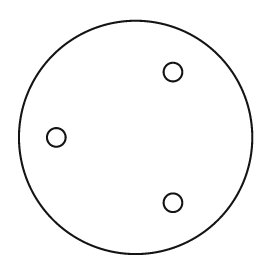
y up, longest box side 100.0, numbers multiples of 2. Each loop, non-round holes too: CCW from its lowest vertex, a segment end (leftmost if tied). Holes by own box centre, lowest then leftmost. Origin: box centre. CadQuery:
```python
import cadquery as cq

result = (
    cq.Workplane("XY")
    .moveTo(0.0, 0.0)
    .circle(50.0)
    .moveTo(16.0, -28.0)
    .circle(4.0)
    .moveTo(-34.0, 0.0)
    .circle(4.0)
    .moveTo(16.0, 28.0)
    .circle(4.0)
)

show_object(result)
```